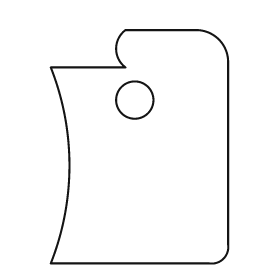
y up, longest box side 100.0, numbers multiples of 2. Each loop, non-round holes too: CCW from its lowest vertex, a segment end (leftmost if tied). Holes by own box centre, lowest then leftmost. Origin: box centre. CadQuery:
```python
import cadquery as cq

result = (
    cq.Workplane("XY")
    .moveTo(-38.0, -50.0)
    .lineTo(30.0, -50.0)
    .threePointArc((36.0, -48.0), (38.0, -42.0))
    .lineTo(38.0, 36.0)
    .threePointArc((34.0, 46.0), (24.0, 50.0))
    .lineTo(-6.0, 50.0)
    .threePointArc((-10.0, 42.0), (-6.0, 34.0))
    .lineTo(-38.0, 34.0)
    .threePointArc((-30.0, -8.0), (-38.0, -50.0))
    .close()
    .moveTo(-2.0, 20.0)
    .circle(8.0)
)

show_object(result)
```